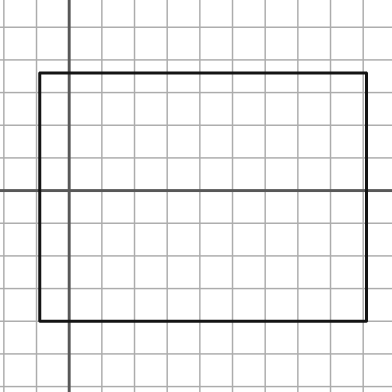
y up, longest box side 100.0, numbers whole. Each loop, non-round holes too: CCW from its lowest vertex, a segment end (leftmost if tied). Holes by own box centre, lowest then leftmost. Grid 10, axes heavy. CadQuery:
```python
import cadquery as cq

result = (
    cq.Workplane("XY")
    .moveTo(-9.0, -40.0)
    .lineTo(91.0, -40.0)
    .lineTo(91.0, 36.0)
    .lineTo(-9.0, 36.0)
    .close()
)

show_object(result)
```